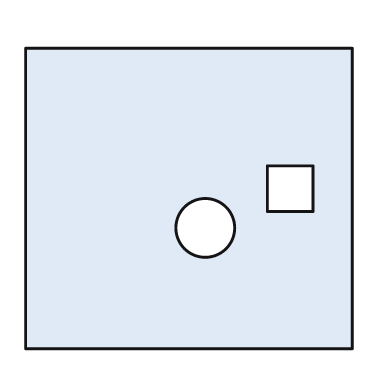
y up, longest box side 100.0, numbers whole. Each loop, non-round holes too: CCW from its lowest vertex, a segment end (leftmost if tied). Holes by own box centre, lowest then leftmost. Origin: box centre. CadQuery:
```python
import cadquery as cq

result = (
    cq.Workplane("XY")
    .moveTo(-50.0, -46.0)
    .lineTo(50.0, -46.0)
    .lineTo(50.0, 46.0)
    .lineTo(-50.0, 46.0)
    .close()
    .moveTo(5.0, -9.0)
    .circle(9.0)
    .moveTo(24.0, -4.0)
    .lineTo(38.0, -4.0)
    .lineTo(38.0, 10.0)
    .lineTo(24.0, 10.0)
    .close()
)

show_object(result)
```